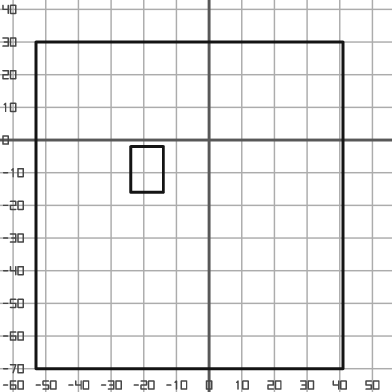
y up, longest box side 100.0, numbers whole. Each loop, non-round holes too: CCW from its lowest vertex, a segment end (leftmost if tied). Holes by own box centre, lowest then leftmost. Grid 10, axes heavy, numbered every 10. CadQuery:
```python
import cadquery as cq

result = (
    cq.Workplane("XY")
    .moveTo(-53.0, -70.0)
    .lineTo(41.0, -70.0)
    .lineTo(41.0, 30.0)
    .lineTo(-53.0, 30.0)
    .close()
    .moveTo(-24.0, -16.0)
    .lineTo(-14.0, -16.0)
    .lineTo(-14.0, -2.0)
    .lineTo(-24.0, -2.0)
    .close()
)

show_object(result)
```